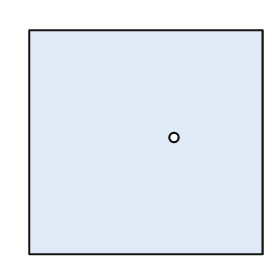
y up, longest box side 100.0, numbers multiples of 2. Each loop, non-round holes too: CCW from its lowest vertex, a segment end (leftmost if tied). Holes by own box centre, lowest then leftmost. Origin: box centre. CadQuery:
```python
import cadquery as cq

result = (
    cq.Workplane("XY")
    .moveTo(-50.0, -48.0)
    .lineTo(50.0, -48.0)
    .lineTo(50.0, 48.0)
    .lineTo(-50.0, 48.0)
    .close()
    .moveTo(12.0, 2.0)
    .circle(2.0)
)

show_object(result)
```